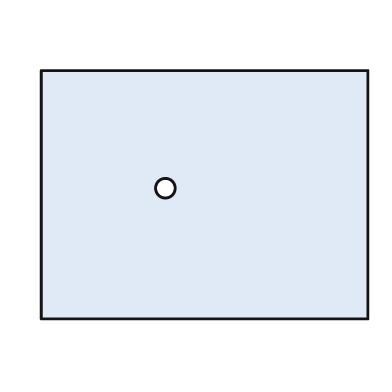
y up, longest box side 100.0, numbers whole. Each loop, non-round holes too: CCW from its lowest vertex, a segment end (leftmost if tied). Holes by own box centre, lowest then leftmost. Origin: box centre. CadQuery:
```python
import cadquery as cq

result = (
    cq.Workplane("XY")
    .moveTo(-50.0, -38.0)
    .lineTo(50.0, -38.0)
    .lineTo(50.0, 38.0)
    .lineTo(-50.0, 38.0)
    .close()
    .moveTo(-12.0, 2.0)
    .circle(3.0)
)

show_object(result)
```